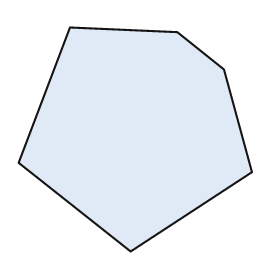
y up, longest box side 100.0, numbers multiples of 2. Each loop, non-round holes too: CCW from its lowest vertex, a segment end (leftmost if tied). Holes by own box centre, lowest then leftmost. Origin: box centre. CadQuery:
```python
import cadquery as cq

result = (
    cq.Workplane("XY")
    .moveTo(-2.0, -48.0)
    .lineTo(50.0, -14.0)
    .lineTo(38.0, 30.0)
    .lineTo(18.0, 46.0)
    .lineTo(-28.0, 48.0)
    .lineTo(-50.0, -10.0)
    .close()
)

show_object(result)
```